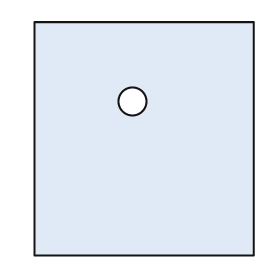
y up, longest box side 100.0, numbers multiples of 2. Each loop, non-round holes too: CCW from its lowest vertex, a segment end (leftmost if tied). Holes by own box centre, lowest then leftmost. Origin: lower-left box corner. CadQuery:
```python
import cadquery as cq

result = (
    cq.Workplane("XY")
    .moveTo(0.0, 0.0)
    .lineTo(94.0, 0.0)
    .lineTo(94.0, 100.0)
    .lineTo(0.0, 100.0)
    .close()
    .moveTo(42.0, 66.0)
    .circle(6.0)
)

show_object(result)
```